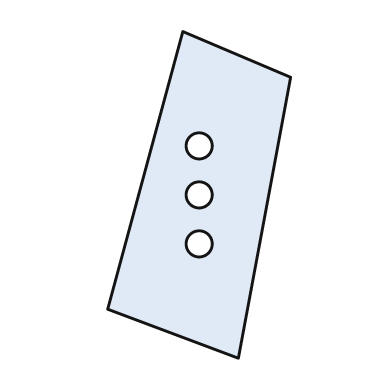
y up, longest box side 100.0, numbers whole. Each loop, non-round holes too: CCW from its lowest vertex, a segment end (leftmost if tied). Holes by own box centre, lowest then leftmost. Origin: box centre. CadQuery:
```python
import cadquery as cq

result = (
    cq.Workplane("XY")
    .moveTo(12.0, -50.0)
    .lineTo(28.0, 36.0)
    .lineTo(-5.0, 50.0)
    .lineTo(-28.0, -35.0)
    .close()
    .moveTo(0.0, -15.0)
    .circle(4.0)
    .moveTo(0.0, 0.0)
    .circle(4.0)
    .moveTo(0.0, 15.0)
    .circle(4.0)
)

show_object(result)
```